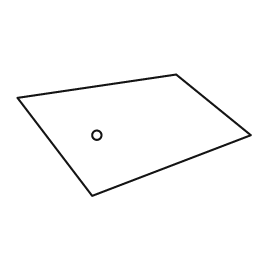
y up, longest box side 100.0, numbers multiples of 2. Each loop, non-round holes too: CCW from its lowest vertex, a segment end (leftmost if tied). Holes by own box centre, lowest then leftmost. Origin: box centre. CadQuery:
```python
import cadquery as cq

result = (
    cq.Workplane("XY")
    .moveTo(-18.0, -26.0)
    .lineTo(50.0, 0.0)
    .lineTo(18.0, 26.0)
    .lineTo(-50.0, 16.0)
    .close()
    .moveTo(-16.0, 0.0)
    .circle(2.0)
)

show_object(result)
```